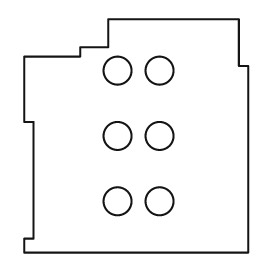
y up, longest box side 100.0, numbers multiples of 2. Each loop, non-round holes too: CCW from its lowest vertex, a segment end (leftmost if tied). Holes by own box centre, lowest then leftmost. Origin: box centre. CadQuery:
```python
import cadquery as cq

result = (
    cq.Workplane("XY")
    .moveTo(-48.0, -50.0)
    .lineTo(48.0, -50.0)
    .lineTo(48.0, 30.0)
    .lineTo(44.0, 30.0)
    .lineTo(44.0, 50.0)
    .lineTo(-12.0, 50.0)
    .lineTo(-12.0, 38.0)
    .lineTo(-24.0, 38.0)
    .lineTo(-24.0, 34.0)
    .lineTo(-48.0, 34.0)
    .lineTo(-48.0, 6.0)
    .lineTo(-44.0, 6.0)
    .lineTo(-44.0, -44.0)
    .lineTo(-48.0, -44.0)
    .close()
    .moveTo(-8.0, -28.0)
    .circle(6.0)
    .moveTo(10.0, -28.0)
    .circle(6.0)
    .moveTo(-8.0, 0.0)
    .circle(6.0)
    .moveTo(10.0, 0.0)
    .circle(6.0)
    .moveTo(-8.0, 28.0)
    .circle(6.0)
    .moveTo(10.0, 28.0)
    .circle(6.0)
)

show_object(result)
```